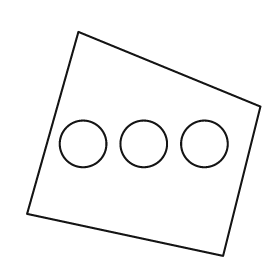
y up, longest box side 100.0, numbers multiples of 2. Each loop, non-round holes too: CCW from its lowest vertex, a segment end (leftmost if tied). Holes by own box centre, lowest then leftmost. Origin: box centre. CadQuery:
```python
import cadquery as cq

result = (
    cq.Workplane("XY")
    .moveTo(34.0, -48.0)
    .lineTo(50.0, 16.0)
    .lineTo(-28.0, 48.0)
    .lineTo(-50.0, -30.0)
    .close()
    .moveTo(-26.0, 0.0)
    .circle(10.0)
    .moveTo(0.0, 0.0)
    .circle(10.0)
    .moveTo(26.0, 0.0)
    .circle(10.0)
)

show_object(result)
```